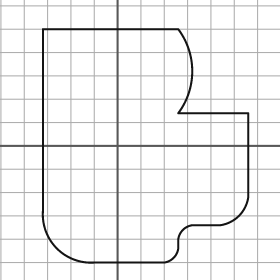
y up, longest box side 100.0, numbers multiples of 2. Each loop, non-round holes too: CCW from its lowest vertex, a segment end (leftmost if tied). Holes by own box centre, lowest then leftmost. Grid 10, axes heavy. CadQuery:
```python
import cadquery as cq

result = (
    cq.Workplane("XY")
    .moveTo(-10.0, -50.0)
    .lineTo(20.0, -50.0)
    .threePointArc((24.0, -48.0), (26.0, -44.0))
    .lineTo(26.0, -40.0)
    .threePointArc((28.0, -36.0), (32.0, -34.0))
    .lineTo(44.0, -34.0)
    .threePointArc((52.0, -30.0), (56.0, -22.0))
    .lineTo(56.0, 14.0)
    .lineTo(26.0, 14.0)
    .threePointArc((32.0, 32.0), (26.0, 50.0))
    .lineTo(-32.0, 50.0)
    .lineTo(-32.0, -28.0)
    .threePointArc((-26.0, -44.0), (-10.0, -50.0))
    .close()
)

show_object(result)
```